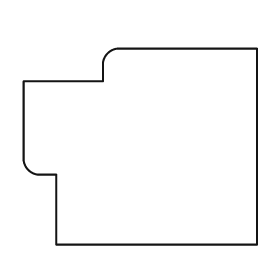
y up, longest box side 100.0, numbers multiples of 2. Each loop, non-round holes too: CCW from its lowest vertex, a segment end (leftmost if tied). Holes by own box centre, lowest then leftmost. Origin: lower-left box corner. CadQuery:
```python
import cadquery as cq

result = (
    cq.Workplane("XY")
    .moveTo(14.0, 0.0)
    .lineTo(100.0, 0.0)
    .lineTo(100.0, 84.0)
    .lineTo(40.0, 84.0)
    .threePointArc((36.0, 82.0), (34.0, 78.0))
    .lineTo(34.0, 70.0)
    .lineTo(0.0, 70.0)
    .lineTo(0.0, 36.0)
    .threePointArc((2.0, 32.0), (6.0, 30.0))
    .lineTo(14.0, 30.0)
    .close()
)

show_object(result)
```